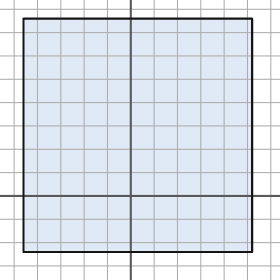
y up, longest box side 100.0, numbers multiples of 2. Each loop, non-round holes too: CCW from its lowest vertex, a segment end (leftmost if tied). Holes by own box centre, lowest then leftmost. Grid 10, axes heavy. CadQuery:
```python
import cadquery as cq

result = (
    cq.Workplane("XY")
    .moveTo(-46.0, -24.0)
    .lineTo(52.0, -24.0)
    .lineTo(52.0, 76.0)
    .lineTo(-46.0, 76.0)
    .close()
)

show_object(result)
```